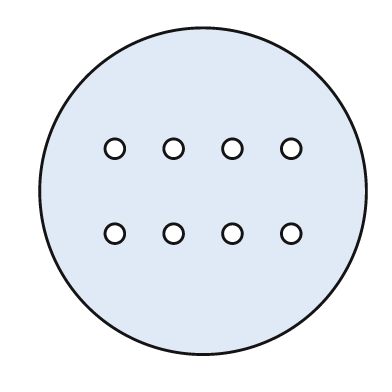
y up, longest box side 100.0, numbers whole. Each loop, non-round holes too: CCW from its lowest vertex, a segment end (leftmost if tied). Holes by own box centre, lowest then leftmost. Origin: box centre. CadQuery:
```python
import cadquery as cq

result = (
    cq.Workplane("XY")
    .moveTo(0.0, 0.0)
    .circle(50.0)
    .moveTo(-27.0, -13.0)
    .circle(3.0)
    .moveTo(-9.0, -13.0)
    .circle(3.0)
    .moveTo(9.0, -13.0)
    .circle(3.0)
    .moveTo(27.0, -13.0)
    .circle(3.0)
    .moveTo(-27.0, 13.0)
    .circle(3.0)
    .moveTo(-9.0, 13.0)
    .circle(3.0)
    .moveTo(9.0, 13.0)
    .circle(3.0)
    .moveTo(27.0, 13.0)
    .circle(3.0)
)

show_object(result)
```